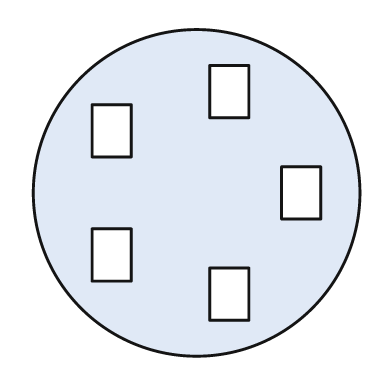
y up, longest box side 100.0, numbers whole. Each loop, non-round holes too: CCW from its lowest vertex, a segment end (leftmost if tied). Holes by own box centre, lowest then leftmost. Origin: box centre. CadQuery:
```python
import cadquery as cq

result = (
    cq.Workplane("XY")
    .moveTo(0.0, 0.0)
    .circle(50.0)
    .moveTo(4.0, -39.0)
    .lineTo(16.0, -39.0)
    .lineTo(16.0, -23.0)
    .lineTo(4.0, -23.0)
    .close()
    .moveTo(-32.0, -27.0)
    .lineTo(-20.0, -27.0)
    .lineTo(-20.0, -11.0)
    .lineTo(-32.0, -11.0)
    .close()
    .moveTo(26.0, -8.0)
    .lineTo(38.0, -8.0)
    .lineTo(38.0, 8.0)
    .lineTo(26.0, 8.0)
    .close()
    .moveTo(-32.0, 11.0)
    .lineTo(-20.0, 11.0)
    .lineTo(-20.0, 27.0)
    .lineTo(-32.0, 27.0)
    .close()
    .moveTo(4.0, 23.0)
    .lineTo(16.0, 23.0)
    .lineTo(16.0, 39.0)
    .lineTo(4.0, 39.0)
    .close()
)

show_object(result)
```